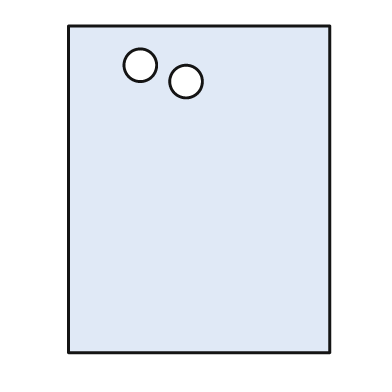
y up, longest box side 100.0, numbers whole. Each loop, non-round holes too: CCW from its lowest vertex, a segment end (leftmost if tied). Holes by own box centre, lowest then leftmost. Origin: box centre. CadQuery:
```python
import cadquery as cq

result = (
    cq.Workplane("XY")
    .moveTo(-40.0, -50.0)
    .lineTo(40.0, -50.0)
    .lineTo(40.0, 50.0)
    .lineTo(-40.0, 50.0)
    .close()
    .moveTo(-4.0, 33.0)
    .circle(5.0)
    .moveTo(-18.0, 38.0)
    .circle(5.0)
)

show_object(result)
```